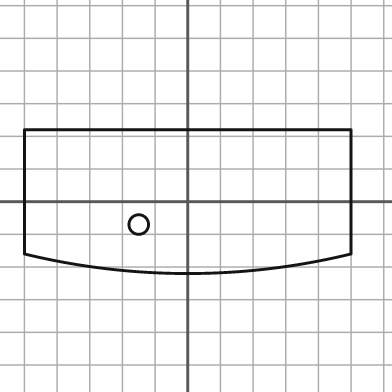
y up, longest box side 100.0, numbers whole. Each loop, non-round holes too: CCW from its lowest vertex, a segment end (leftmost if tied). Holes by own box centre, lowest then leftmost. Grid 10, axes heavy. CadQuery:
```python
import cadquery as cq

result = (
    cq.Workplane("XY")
    .moveTo(-50.0, -16.0)
    .threePointArc((0.0, -22.0), (50.0, -16.0))
    .lineTo(50.0, 22.0)
    .lineTo(-50.0, 22.0)
    .close()
    .moveTo(-15.0, -7.0)
    .circle(3.0)
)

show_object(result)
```